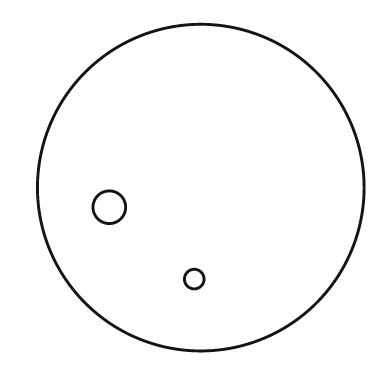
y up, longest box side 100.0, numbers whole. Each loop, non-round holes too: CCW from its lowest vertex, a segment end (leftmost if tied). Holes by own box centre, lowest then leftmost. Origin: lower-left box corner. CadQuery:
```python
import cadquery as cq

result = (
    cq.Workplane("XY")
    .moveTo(50.0, 50.0)
    .circle(50.0)
    .moveTo(48.0, 22.0)
    .circle(3.0)
    .moveTo(22.0, 44.0)
    .circle(5.0)
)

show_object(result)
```